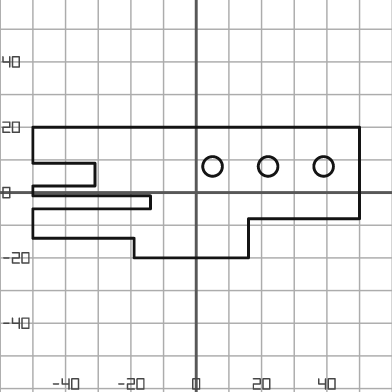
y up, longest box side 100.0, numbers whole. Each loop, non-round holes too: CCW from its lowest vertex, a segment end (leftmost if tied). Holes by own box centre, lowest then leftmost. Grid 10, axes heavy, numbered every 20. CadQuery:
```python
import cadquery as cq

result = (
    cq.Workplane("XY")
    .moveTo(-19.0, -20.0)
    .lineTo(16.0, -20.0)
    .lineTo(16.0, -8.0)
    .lineTo(50.0, -8.0)
    .lineTo(50.0, 20.0)
    .lineTo(-50.0, 20.0)
    .lineTo(-50.0, 9.0)
    .lineTo(-31.0, 9.0)
    .lineTo(-31.0, 2.0)
    .lineTo(-50.0, 2.0)
    .lineTo(-50.0, -1.0)
    .lineTo(-14.0, -1.0)
    .lineTo(-14.0, -5.0)
    .lineTo(-50.0, -5.0)
    .lineTo(-50.0, -14.0)
    .lineTo(-19.0, -14.0)
    .close()
    .moveTo(5.0, 8.0)
    .circle(3.0)
    .moveTo(22.0, 8.0)
    .circle(3.0)
    .moveTo(39.0, 8.0)
    .circle(3.0)
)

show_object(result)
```